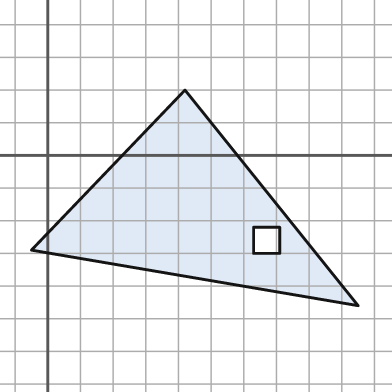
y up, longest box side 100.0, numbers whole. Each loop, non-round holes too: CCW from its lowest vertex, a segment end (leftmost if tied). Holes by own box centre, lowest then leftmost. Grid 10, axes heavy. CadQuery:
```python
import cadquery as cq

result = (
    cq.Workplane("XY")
    .moveTo(95.0, -46.0)
    .lineTo(42.0, 20.0)
    .lineTo(-5.0, -29.0)
    .close()
    .moveTo(63.0, -30.0)
    .lineTo(71.0, -30.0)
    .lineTo(71.0, -22.0)
    .lineTo(63.0, -22.0)
    .close()
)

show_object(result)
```